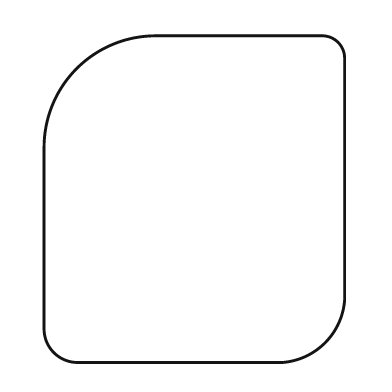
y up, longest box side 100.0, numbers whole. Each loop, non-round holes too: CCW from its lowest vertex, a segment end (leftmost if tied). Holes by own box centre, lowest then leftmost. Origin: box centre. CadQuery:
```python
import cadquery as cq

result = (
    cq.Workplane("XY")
    .moveTo(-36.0, -50.0)
    .lineTo(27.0, -50.0)
    .threePointArc((40.0, -44.0), (46.0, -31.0))
    .lineTo(46.0, 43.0)
    .threePointArc((44.0, 48.0), (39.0, 50.0))
    .lineTo(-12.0, 50.0)
    .threePointArc((-36.0, 40.0), (-46.0, 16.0))
    .lineTo(-46.0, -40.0)
    .threePointArc((-43.0, -47.0), (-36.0, -50.0))
    .close()
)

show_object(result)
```